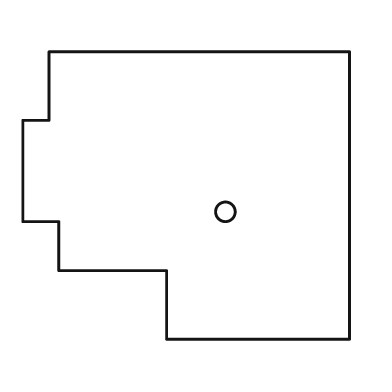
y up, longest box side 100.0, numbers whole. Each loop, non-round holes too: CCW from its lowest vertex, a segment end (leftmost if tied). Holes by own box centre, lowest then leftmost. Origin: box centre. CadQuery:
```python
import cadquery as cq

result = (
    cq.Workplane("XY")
    .moveTo(-6.0, -44.0)
    .lineTo(50.0, -44.0)
    .lineTo(50.0, 44.0)
    .lineTo(-42.0, 44.0)
    .lineTo(-42.0, 23.0)
    .lineTo(-50.0, 23.0)
    .lineTo(-50.0, -8.0)
    .lineTo(-39.0, -8.0)
    .lineTo(-39.0, -23.0)
    .lineTo(-6.0, -23.0)
    .close()
    .moveTo(12.0, -5.0)
    .circle(3.0)
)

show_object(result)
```